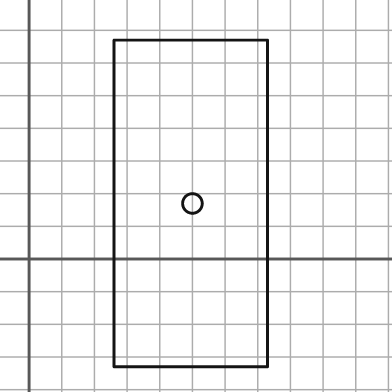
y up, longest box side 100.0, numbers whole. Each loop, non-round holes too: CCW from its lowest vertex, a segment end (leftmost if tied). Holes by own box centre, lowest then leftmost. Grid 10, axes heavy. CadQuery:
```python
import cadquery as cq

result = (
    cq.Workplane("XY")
    .moveTo(26.0, -33.0)
    .lineTo(73.0, -33.0)
    .lineTo(73.0, 67.0)
    .lineTo(26.0, 67.0)
    .close()
    .moveTo(50.0, 17.0)
    .circle(3.0)
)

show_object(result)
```